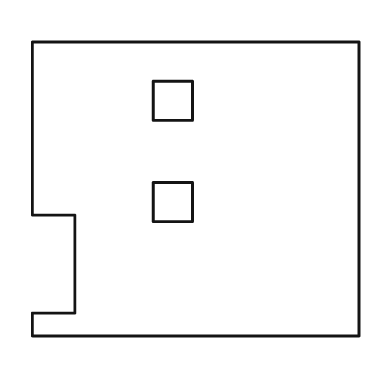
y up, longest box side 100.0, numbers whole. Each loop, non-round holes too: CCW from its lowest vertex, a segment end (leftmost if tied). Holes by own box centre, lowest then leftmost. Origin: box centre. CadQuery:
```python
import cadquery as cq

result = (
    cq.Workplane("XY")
    .moveTo(-50.0, -45.0)
    .lineTo(50.0, -45.0)
    .lineTo(50.0, 45.0)
    .lineTo(-50.0, 45.0)
    .lineTo(-50.0, -8.0)
    .lineTo(-37.0, -8.0)
    .lineTo(-37.0, -38.0)
    .lineTo(-50.0, -38.0)
    .close()
    .moveTo(-13.0, -10.0)
    .lineTo(-1.0, -10.0)
    .lineTo(-1.0, 2.0)
    .lineTo(-13.0, 2.0)
    .close()
    .moveTo(-13.0, 21.0)
    .lineTo(-1.0, 21.0)
    .lineTo(-1.0, 33.0)
    .lineTo(-13.0, 33.0)
    .close()
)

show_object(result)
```